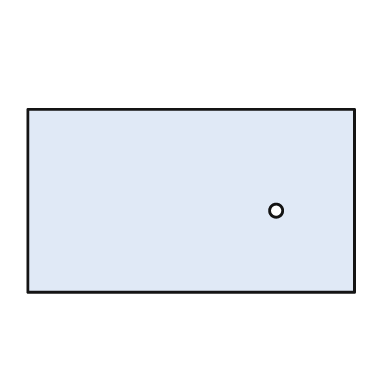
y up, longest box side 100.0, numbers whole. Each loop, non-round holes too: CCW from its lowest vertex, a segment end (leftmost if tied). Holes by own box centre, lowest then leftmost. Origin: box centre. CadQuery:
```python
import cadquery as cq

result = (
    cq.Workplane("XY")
    .moveTo(-50.0, -28.0)
    .lineTo(50.0, -28.0)
    .lineTo(50.0, 28.0)
    .lineTo(-50.0, 28.0)
    .close()
    .moveTo(26.0, -3.0)
    .circle(2.0)
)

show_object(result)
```